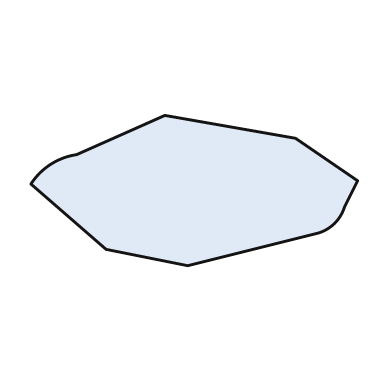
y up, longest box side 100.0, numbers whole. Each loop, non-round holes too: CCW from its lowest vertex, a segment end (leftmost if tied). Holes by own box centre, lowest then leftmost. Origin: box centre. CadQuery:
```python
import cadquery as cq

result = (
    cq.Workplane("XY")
    .moveTo(-2.0, -23.0)
    .lineTo(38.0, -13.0)
    .threePointArc((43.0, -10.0), (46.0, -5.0))
    .lineTo(50.0, 3.0)
    .lineTo(31.0, 16.0)
    .lineTo(-9.0, 23.0)
    .lineTo(-36.0, 11.0)
    .threePointArc((-44.0, 8.0), (-50.0, 2.0))
    .lineTo(-27.0, -18.0)
    .close()
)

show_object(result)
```